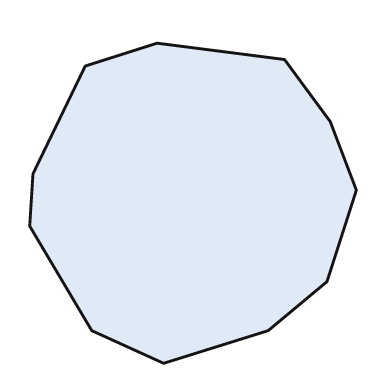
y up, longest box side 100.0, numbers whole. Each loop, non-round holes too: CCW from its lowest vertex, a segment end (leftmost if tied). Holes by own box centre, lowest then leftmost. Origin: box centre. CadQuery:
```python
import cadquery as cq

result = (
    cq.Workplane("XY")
    .moveTo(-9.0, -49.0)
    .lineTo(23.0, -39.0)
    .lineTo(41.0, -24.0)
    .lineTo(50.0, 4.0)
    .lineTo(42.0, 25.0)
    .lineTo(28.0, 44.0)
    .lineTo(-11.0, 49.0)
    .lineTo(-33.0, 42.0)
    .lineTo(-49.0, 9.0)
    .lineTo(-50.0, -7.0)
    .lineTo(-31.0, -39.0)
    .close()
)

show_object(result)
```